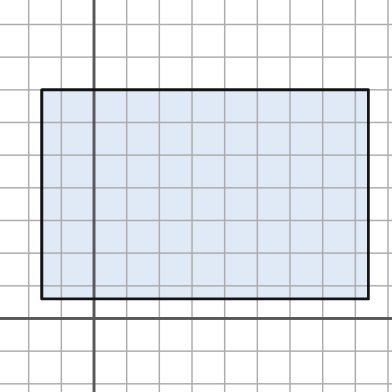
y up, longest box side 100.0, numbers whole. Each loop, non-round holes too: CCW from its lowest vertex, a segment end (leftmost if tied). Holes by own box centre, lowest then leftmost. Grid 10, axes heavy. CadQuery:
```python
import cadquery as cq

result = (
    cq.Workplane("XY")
    .moveTo(-16.0, 6.0)
    .lineTo(84.0, 6.0)
    .lineTo(84.0, 70.0)
    .lineTo(-16.0, 70.0)
    .close()
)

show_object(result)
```